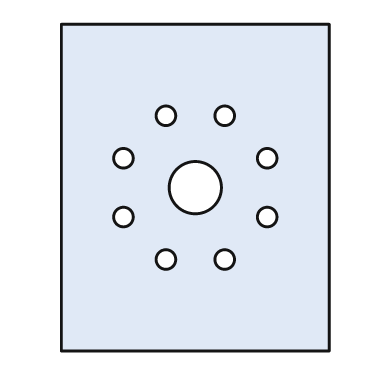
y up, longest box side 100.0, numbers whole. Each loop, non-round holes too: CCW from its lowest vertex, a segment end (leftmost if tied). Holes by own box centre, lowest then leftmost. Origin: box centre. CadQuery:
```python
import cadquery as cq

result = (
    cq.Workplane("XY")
    .moveTo(-41.0, -50.0)
    .lineTo(41.0, -50.0)
    .lineTo(41.0, 50.0)
    .lineTo(-41.0, 50.0)
    .close()
    .moveTo(-9.0, -22.0)
    .circle(3.0)
    .moveTo(9.0, -22.0)
    .circle(3.0)
    .moveTo(-22.0, -9.0)
    .circle(3.0)
    .moveTo(22.0, -9.0)
    .circle(3.0)
    .moveTo(0.0, 0.0)
    .circle(8.0)
    .moveTo(-22.0, 9.0)
    .circle(3.0)
    .moveTo(22.0, 9.0)
    .circle(3.0)
    .moveTo(-9.0, 22.0)
    .circle(3.0)
    .moveTo(9.0, 22.0)
    .circle(3.0)
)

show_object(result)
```